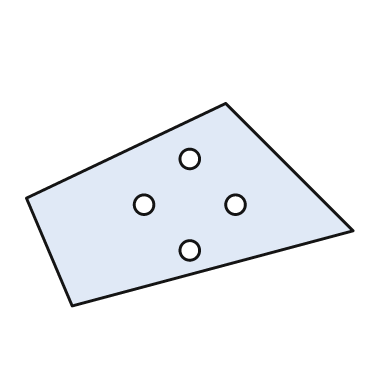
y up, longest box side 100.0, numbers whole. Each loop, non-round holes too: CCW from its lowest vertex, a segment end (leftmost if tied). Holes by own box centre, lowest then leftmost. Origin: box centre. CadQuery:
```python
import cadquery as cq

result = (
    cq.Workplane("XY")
    .moveTo(-36.0, -31.0)
    .lineTo(50.0, -8.0)
    .lineTo(11.0, 31.0)
    .lineTo(-50.0, 2.0)
    .close()
    .moveTo(0.0, -14.0)
    .circle(3.0)
    .moveTo(-14.0, 0.0)
    .circle(3.0)
    .moveTo(14.0, 0.0)
    .circle(3.0)
    .moveTo(0.0, 14.0)
    .circle(3.0)
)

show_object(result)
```